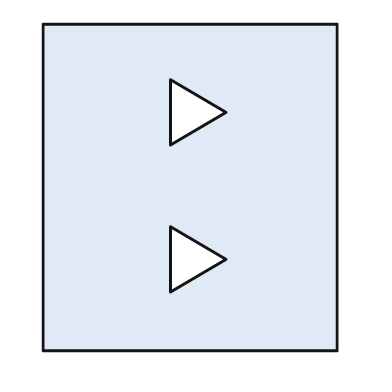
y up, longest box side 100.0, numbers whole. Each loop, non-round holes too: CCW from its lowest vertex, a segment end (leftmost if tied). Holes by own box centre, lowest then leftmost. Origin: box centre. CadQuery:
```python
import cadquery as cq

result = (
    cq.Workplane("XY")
    .moveTo(-45.0, -50.0)
    .lineTo(45.0, -50.0)
    .lineTo(45.0, 50.0)
    .lineTo(-45.0, 50.0)
    .close()
    .moveTo(-6.0, -32.0)
    .lineTo(11.0, -22.0)
    .lineTo(-6.0, -12.0)
    .close()
    .moveTo(-6.0, 13.0)
    .lineTo(11.0, 23.0)
    .lineTo(-6.0, 33.0)
    .close()
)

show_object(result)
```